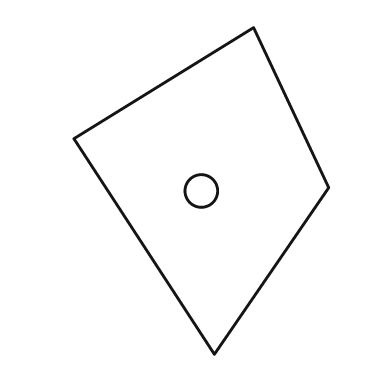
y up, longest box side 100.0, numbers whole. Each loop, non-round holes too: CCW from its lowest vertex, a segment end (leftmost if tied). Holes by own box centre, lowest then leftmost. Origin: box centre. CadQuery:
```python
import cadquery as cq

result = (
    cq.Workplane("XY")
    .moveTo(4.0, -50.0)
    .lineTo(39.0, 1.0)
    .lineTo(16.0, 50.0)
    .lineTo(-39.0, 16.0)
    .close()
    .moveTo(0.0, 0.0)
    .circle(5.0)
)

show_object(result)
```